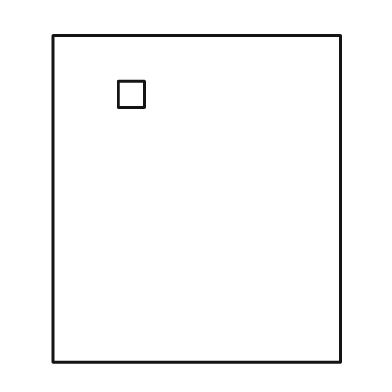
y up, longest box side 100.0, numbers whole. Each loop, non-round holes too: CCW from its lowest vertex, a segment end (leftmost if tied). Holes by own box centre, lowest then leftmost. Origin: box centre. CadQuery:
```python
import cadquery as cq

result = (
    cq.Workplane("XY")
    .moveTo(-44.0, -50.0)
    .lineTo(44.0, -50.0)
    .lineTo(44.0, 50.0)
    .lineTo(-44.0, 50.0)
    .close()
    .moveTo(-24.0, 28.0)
    .lineTo(-16.0, 28.0)
    .lineTo(-16.0, 36.0)
    .lineTo(-24.0, 36.0)
    .close()
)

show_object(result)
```